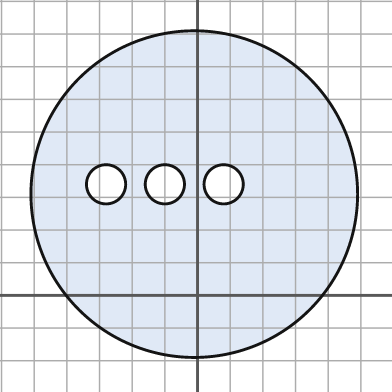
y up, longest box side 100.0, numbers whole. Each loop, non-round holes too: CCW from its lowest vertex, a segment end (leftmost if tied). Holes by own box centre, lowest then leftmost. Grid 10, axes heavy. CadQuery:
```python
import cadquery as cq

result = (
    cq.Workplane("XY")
    .moveTo(-1.0, 31.0)
    .circle(50.0)
    .moveTo(-28.0, 34.0)
    .circle(6.0)
    .moveTo(-10.0, 34.0)
    .circle(6.0)
    .moveTo(8.0, 34.0)
    .circle(6.0)
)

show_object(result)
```